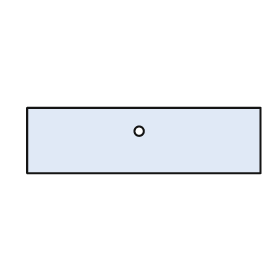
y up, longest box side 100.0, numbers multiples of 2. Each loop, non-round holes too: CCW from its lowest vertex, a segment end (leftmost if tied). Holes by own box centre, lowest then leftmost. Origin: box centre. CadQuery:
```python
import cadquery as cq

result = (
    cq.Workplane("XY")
    .moveTo(-50.0, -14.0)
    .lineTo(50.0, -14.0)
    .lineTo(50.0, 14.0)
    .lineTo(-50.0, 14.0)
    .close()
    .moveTo(-2.0, 4.0)
    .circle(2.0)
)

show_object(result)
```